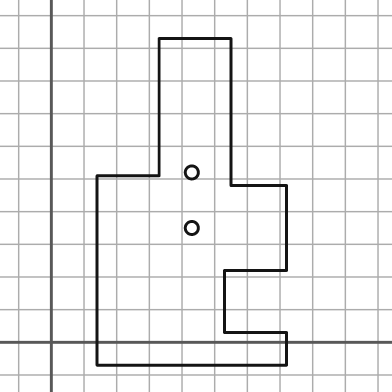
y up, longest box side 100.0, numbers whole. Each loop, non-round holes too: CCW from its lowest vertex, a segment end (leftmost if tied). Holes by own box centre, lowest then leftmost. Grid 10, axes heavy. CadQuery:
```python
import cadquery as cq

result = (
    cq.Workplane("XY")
    .moveTo(14.0, -7.0)
    .lineTo(72.0, -7.0)
    .lineTo(72.0, 3.0)
    .lineTo(53.0, 3.0)
    .lineTo(53.0, 22.0)
    .lineTo(72.0, 22.0)
    .lineTo(72.0, 48.0)
    .lineTo(55.0, 48.0)
    .lineTo(55.0, 93.0)
    .lineTo(33.0, 93.0)
    .lineTo(33.0, 51.0)
    .lineTo(14.0, 51.0)
    .close()
    .moveTo(43.0, 35.0)
    .circle(2.0)
    .moveTo(43.0, 52.0)
    .circle(2.0)
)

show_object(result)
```